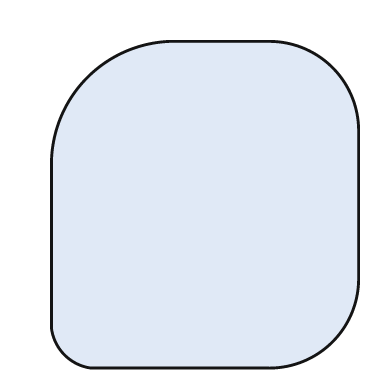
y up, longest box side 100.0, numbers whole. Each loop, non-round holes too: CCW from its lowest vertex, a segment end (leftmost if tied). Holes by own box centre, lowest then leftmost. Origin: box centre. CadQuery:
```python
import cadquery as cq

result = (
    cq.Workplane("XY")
    .moveTo(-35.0, -50.0)
    .lineTo(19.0, -50.0)
    .threePointArc((39.0, -42.0), (47.0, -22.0))
    .lineTo(47.0, 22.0)
    .threePointArc((39.0, 42.0), (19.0, 50.0))
    .lineTo(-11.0, 50.0)
    .threePointArc((-36.0, 39.0), (-47.0, 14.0))
    .lineTo(-47.0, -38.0)
    .threePointArc((-43.0, -46.0), (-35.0, -50.0))
    .close()
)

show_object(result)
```